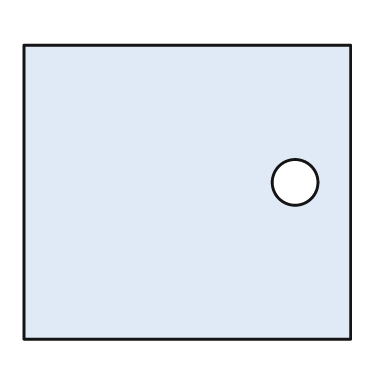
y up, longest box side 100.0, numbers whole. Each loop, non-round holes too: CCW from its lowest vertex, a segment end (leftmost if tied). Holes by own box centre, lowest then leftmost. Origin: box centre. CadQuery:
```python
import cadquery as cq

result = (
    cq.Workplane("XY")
    .moveTo(-50.0, -45.0)
    .lineTo(50.0, -45.0)
    .lineTo(50.0, 45.0)
    .lineTo(-50.0, 45.0)
    .close()
    .moveTo(33.0, 3.0)
    .circle(7.0)
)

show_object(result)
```